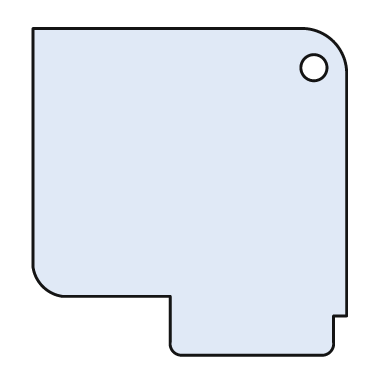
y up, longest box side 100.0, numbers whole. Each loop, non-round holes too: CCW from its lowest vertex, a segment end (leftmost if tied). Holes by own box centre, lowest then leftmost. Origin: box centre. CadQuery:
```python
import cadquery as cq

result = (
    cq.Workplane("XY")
    .moveTo(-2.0, -50.0)
    .lineTo(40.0, -50.0)
    .threePointArc((43.0, -49.0), (44.0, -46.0))
    .lineTo(44.0, -38.0)
    .lineTo(48.0, -38.0)
    .lineTo(48.0, 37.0)
    .threePointArc((44.0, 46.0), (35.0, 50.0))
    .lineTo(-48.0, 50.0)
    .lineTo(-48.0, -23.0)
    .threePointArc((-45.0, -29.0), (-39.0, -32.0))
    .lineTo(-6.0, -32.0)
    .lineTo(-6.0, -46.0)
    .threePointArc((-5.0, -49.0), (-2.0, -50.0))
    .close()
    .moveTo(38.0, 38.0)
    .circle(4.0)
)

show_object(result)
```